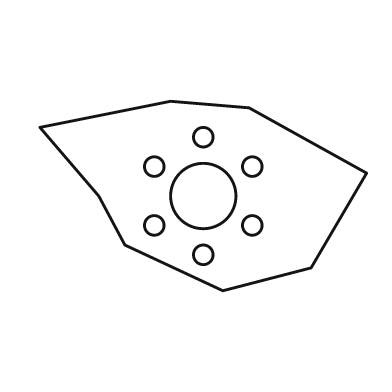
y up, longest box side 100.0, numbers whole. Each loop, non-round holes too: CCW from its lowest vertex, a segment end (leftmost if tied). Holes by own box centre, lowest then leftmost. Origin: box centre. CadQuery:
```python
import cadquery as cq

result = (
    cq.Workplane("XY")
    .moveTo(6.0, -29.0)
    .lineTo(33.0, -22.0)
    .lineTo(50.0, 7.0)
    .lineTo(14.0, 27.0)
    .lineTo(-10.0, 29.0)
    .lineTo(-50.0, 21.0)
    .lineTo(-32.0, 0.0)
    .lineTo(-24.0, -15.0)
    .close()
    .moveTo(0.0, -18.0)
    .circle(3.0)
    .moveTo(-15.0, -9.0)
    .circle(3.0)
    .moveTo(15.0, -9.0)
    .circle(3.0)
    .moveTo(0.0, 0.0)
    .circle(10.0)
    .moveTo(-15.0, 9.0)
    .circle(3.0)
    .moveTo(15.0, 9.0)
    .circle(3.0)
    .moveTo(0.0, 18.0)
    .circle(3.0)
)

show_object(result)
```